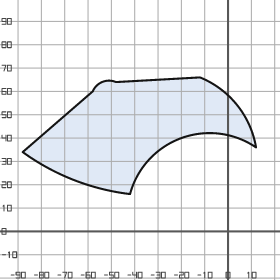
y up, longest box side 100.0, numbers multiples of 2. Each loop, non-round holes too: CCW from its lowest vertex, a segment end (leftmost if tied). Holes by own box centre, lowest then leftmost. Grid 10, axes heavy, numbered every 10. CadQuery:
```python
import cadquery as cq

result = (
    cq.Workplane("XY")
    .moveTo(-42.0, 16.0)
    .threePointArc((-20.0, 40.0), (12.0, 36.0))
    .threePointArc((4.0, 54.0), (-12.0, 66.0))
    .lineTo(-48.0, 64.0)
    .threePointArc((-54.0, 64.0), (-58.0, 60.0))
    .lineTo(-88.0, 34.0)
    .threePointArc((-66.0, 22.0), (-42.0, 16.0))
    .close()
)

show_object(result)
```